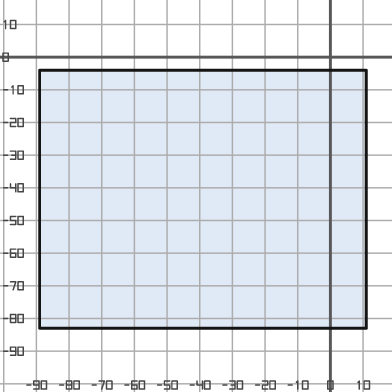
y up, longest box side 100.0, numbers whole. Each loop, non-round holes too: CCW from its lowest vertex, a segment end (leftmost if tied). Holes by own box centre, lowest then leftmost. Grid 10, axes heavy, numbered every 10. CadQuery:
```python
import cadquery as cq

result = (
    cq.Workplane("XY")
    .moveTo(-89.0, -83.0)
    .lineTo(11.0, -83.0)
    .lineTo(11.0, -4.0)
    .lineTo(-89.0, -4.0)
    .close()
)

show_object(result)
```